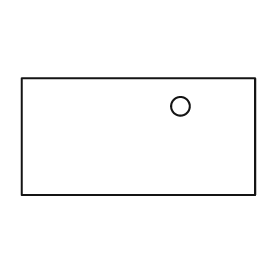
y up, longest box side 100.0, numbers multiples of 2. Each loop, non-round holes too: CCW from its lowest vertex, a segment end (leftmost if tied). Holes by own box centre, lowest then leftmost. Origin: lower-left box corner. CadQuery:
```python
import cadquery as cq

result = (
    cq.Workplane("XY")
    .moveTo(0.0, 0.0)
    .lineTo(100.0, 0.0)
    .lineTo(100.0, 50.0)
    .lineTo(0.0, 50.0)
    .close()
    .moveTo(68.0, 38.0)
    .circle(4.0)
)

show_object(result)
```